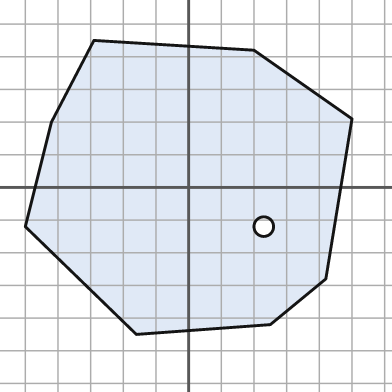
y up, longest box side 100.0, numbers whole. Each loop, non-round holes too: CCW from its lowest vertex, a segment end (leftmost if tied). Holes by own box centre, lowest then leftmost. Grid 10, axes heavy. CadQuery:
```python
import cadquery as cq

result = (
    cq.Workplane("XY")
    .moveTo(-16.0, -45.0)
    .lineTo(25.0, -42.0)
    .lineTo(42.0, -28.0)
    .lineTo(50.0, 21.0)
    .lineTo(20.0, 42.0)
    .lineTo(-29.0, 45.0)
    .lineTo(-42.0, 20.0)
    .lineTo(-50.0, -12.0)
    .close()
    .moveTo(23.0, -12.0)
    .circle(3.0)
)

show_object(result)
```